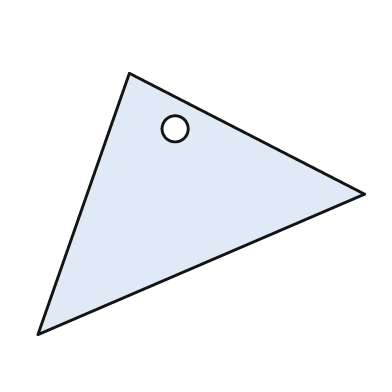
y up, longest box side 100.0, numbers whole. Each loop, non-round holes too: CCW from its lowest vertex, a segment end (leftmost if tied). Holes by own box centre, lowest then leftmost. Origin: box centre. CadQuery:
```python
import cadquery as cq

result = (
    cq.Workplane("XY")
    .moveTo(-50.0, -40.0)
    .lineTo(50.0, 3.0)
    .lineTo(-22.0, 40.0)
    .close()
    .moveTo(-8.0, 23.0)
    .circle(4.0)
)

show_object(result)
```